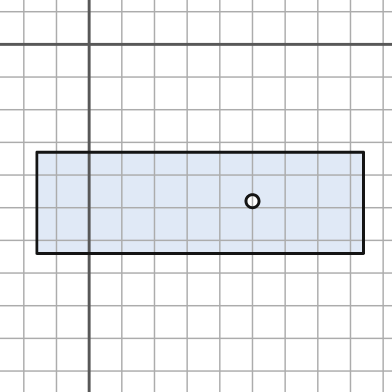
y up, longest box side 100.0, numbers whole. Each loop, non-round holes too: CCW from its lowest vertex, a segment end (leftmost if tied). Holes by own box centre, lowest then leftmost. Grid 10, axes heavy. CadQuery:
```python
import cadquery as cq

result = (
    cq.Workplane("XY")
    .moveTo(-16.0, -64.0)
    .lineTo(84.0, -64.0)
    .lineTo(84.0, -33.0)
    .lineTo(-16.0, -33.0)
    .close()
    .moveTo(50.0, -48.0)
    .circle(2.0)
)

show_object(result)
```